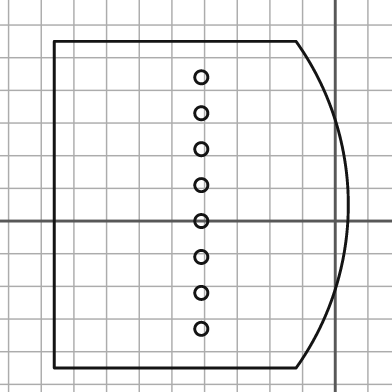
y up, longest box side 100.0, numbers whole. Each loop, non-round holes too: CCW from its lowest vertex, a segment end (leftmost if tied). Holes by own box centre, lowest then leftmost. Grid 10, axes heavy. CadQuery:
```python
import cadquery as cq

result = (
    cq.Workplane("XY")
    .moveTo(-86.0, -45.0)
    .lineTo(-12.0, -45.0)
    .threePointArc((4.0, 5.0), (-12.0, 55.0))
    .lineTo(-86.0, 55.0)
    .close()
    .moveTo(-41.0, -33.0)
    .circle(2.0)
    .moveTo(-41.0, -22.0)
    .circle(2.0)
    .moveTo(-41.0, -11.0)
    .circle(2.0)
    .moveTo(-41.0, 0.0)
    .circle(2.0)
    .moveTo(-41.0, 11.0)
    .circle(2.0)
    .moveTo(-41.0, 22.0)
    .circle(2.0)
    .moveTo(-41.0, 33.0)
    .circle(2.0)
    .moveTo(-41.0, 44.0)
    .circle(2.0)
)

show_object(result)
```